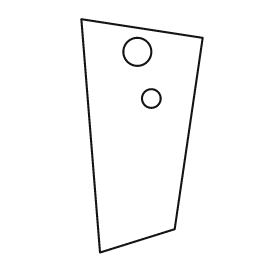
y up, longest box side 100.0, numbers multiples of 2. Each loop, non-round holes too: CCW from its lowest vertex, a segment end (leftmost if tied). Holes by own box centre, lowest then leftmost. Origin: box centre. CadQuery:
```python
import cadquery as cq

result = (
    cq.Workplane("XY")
    .moveTo(-18.0, -50.0)
    .lineTo(14.0, -40.0)
    .lineTo(26.0, 42.0)
    .lineTo(-26.0, 50.0)
    .close()
    .moveTo(4.0, 16.0)
    .circle(4.0)
    .moveTo(-2.0, 36.0)
    .circle(6.0)
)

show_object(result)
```